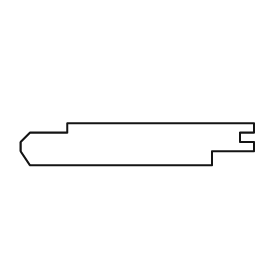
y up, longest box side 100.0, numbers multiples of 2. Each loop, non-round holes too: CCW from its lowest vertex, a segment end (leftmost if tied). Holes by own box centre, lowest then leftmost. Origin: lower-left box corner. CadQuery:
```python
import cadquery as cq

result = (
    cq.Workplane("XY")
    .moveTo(4.0, 0.0)
    .lineTo(82.0, 0.0)
    .lineTo(82.0, 6.0)
    .lineTo(100.0, 6.0)
    .lineTo(100.0, 10.0)
    .lineTo(94.0, 10.0)
    .lineTo(94.0, 14.0)
    .lineTo(100.0, 14.0)
    .lineTo(100.0, 18.0)
    .lineTo(20.0, 18.0)
    .lineTo(20.0, 14.0)
    .lineTo(4.0, 14.0)
    .lineTo(0.0, 10.0)
    .lineTo(0.0, 6.0)
    .close()
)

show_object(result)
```